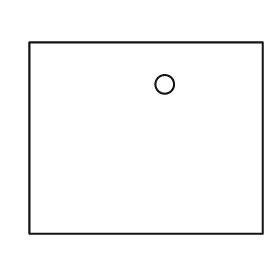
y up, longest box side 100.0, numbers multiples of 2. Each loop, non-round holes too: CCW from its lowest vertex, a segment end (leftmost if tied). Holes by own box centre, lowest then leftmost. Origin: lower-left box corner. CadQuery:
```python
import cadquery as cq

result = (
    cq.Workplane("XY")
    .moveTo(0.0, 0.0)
    .lineTo(100.0, 0.0)
    .lineTo(100.0, 82.0)
    .lineTo(0.0, 82.0)
    .close()
    .moveTo(58.0, 64.0)
    .circle(4.0)
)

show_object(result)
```